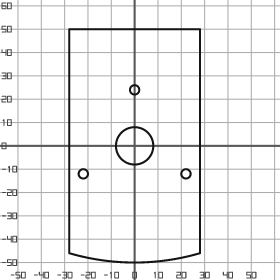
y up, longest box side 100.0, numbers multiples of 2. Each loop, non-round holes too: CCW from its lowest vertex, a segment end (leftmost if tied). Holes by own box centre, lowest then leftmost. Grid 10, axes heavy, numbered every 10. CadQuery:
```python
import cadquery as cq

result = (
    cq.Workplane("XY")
    .moveTo(-28.0, -46.0)
    .threePointArc((0.0, -50.0), (28.0, -46.0))
    .lineTo(28.0, 50.0)
    .lineTo(-28.0, 50.0)
    .close()
    .moveTo(-22.0, -12.0)
    .circle(2.0)
    .moveTo(22.0, -12.0)
    .circle(2.0)
    .moveTo(0.0, 0.0)
    .circle(8.0)
    .moveTo(0.0, 24.0)
    .circle(2.0)
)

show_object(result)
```